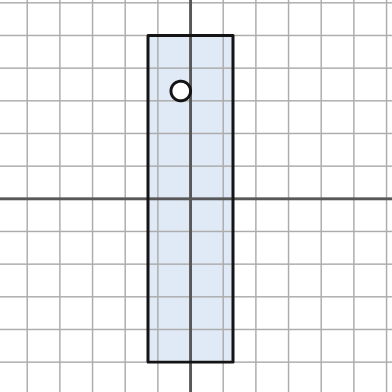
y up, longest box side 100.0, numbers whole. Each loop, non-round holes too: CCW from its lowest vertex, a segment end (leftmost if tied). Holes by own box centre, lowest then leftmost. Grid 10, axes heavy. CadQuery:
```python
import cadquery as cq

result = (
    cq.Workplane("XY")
    .moveTo(-13.0, -50.0)
    .lineTo(13.0, -50.0)
    .lineTo(13.0, 50.0)
    .lineTo(-13.0, 50.0)
    .close()
    .moveTo(-3.0, 33.0)
    .circle(3.0)
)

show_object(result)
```